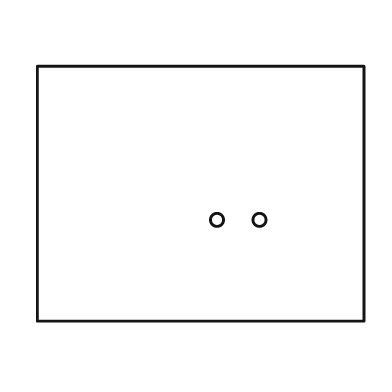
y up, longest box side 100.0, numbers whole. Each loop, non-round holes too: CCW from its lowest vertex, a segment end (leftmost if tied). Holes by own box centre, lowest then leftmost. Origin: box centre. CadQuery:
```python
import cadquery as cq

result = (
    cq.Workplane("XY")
    .moveTo(-50.0, -39.0)
    .lineTo(50.0, -39.0)
    .lineTo(50.0, 39.0)
    .lineTo(-50.0, 39.0)
    .close()
    .moveTo(5.0, -8.0)
    .circle(2.0)
    .moveTo(18.0, -8.0)
    .circle(2.0)
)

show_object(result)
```